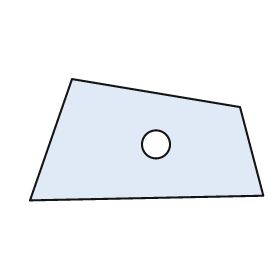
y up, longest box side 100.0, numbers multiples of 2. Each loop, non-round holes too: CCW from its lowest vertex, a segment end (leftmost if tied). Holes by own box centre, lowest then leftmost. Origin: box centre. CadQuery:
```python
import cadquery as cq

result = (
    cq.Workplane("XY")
    .moveTo(-50.0, -26.0)
    .lineTo(50.0, -24.0)
    .lineTo(40.0, 14.0)
    .lineTo(-32.0, 26.0)
    .close()
    .moveTo(4.0, -2.0)
    .circle(6.0)
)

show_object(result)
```